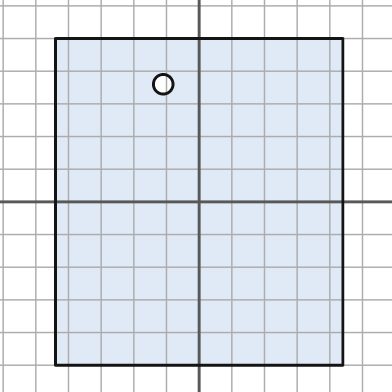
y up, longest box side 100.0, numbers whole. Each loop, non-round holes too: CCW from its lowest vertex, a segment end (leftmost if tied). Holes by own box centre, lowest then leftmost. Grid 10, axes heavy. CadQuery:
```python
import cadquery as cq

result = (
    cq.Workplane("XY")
    .moveTo(-44.0, -50.0)
    .lineTo(44.0, -50.0)
    .lineTo(44.0, 50.0)
    .lineTo(-44.0, 50.0)
    .close()
    .moveTo(-11.0, 36.0)
    .circle(3.0)
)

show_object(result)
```